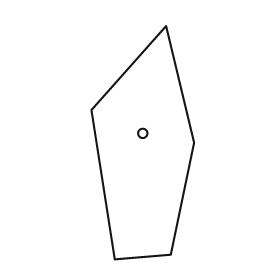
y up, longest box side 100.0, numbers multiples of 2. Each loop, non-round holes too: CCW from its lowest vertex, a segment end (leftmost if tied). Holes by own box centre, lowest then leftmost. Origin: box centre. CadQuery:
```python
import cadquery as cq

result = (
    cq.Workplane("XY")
    .moveTo(-12.0, -50.0)
    .lineTo(12.0, -48.0)
    .lineTo(22.0, 0.0)
    .lineTo(10.0, 50.0)
    .lineTo(-22.0, 14.0)
    .close()
    .moveTo(0.0, 4.0)
    .circle(2.0)
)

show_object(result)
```